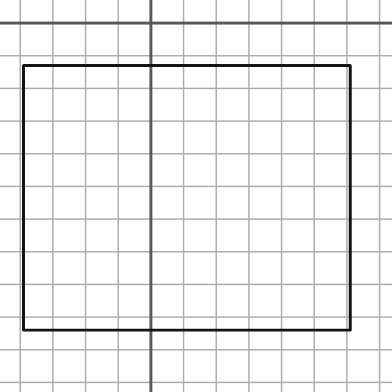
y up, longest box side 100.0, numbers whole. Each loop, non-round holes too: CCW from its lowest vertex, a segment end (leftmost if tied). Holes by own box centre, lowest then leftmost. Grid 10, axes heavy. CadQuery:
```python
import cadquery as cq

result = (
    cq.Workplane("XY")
    .moveTo(-39.0, -94.0)
    .lineTo(61.0, -94.0)
    .lineTo(61.0, -13.0)
    .lineTo(-39.0, -13.0)
    .close()
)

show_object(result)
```